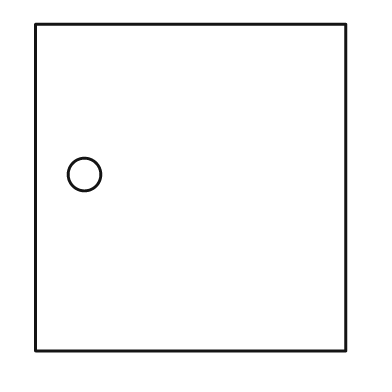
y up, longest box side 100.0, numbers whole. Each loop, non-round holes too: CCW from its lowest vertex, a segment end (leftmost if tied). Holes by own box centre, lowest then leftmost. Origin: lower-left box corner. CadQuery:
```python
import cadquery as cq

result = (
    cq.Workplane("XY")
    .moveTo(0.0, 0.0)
    .lineTo(95.0, 0.0)
    .lineTo(95.0, 100.0)
    .lineTo(0.0, 100.0)
    .close()
    .moveTo(15.0, 54.0)
    .circle(5.0)
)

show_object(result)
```